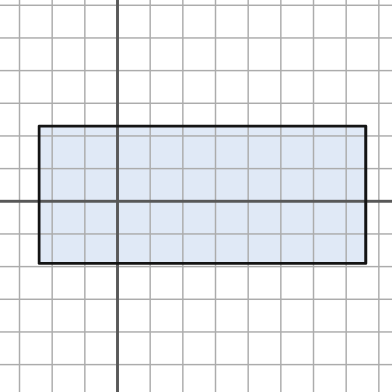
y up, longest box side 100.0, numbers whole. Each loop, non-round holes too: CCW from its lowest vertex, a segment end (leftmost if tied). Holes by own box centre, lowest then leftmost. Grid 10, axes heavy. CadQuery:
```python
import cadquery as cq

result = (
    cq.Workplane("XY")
    .moveTo(-24.0, -19.0)
    .lineTo(76.0, -19.0)
    .lineTo(76.0, 23.0)
    .lineTo(-24.0, 23.0)
    .close()
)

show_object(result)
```